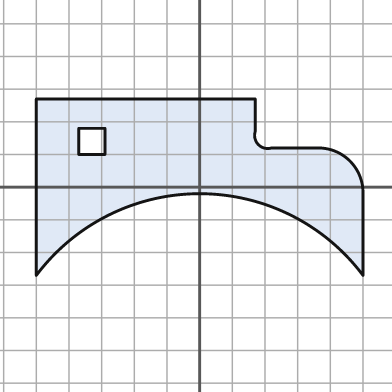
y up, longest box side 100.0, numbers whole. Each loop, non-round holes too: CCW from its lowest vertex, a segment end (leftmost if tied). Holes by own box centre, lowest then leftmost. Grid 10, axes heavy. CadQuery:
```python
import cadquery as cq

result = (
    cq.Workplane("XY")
    .moveTo(-50.0, -27.0)
    .threePointArc((0.0, -2.0), (50.0, -27.0))
    .lineTo(50.0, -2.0)
    .threePointArc((46.0, 8.0), (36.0, 12.0))
    .lineTo(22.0, 12.0)
    .threePointArc((18.0, 13.0), (17.0, 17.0))
    .lineTo(17.0, 27.0)
    .lineTo(-50.0, 27.0)
    .close()
    .moveTo(-37.0, 10.0)
    .lineTo(-29.0, 10.0)
    .lineTo(-29.0, 18.0)
    .lineTo(-37.0, 18.0)
    .close()
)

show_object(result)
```